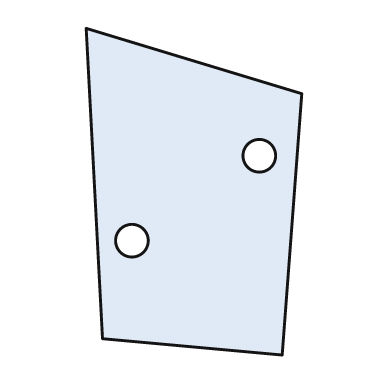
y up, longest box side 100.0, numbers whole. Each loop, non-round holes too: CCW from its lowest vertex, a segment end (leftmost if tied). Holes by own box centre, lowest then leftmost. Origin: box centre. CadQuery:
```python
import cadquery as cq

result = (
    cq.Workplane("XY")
    .moveTo(27.0, -50.0)
    .lineTo(33.0, 30.0)
    .lineTo(-33.0, 50.0)
    .lineTo(-28.0, -45.0)
    .close()
    .moveTo(-19.0, -15.0)
    .circle(5.0)
    .moveTo(20.0, 11.0)
    .circle(5.0)
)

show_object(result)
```